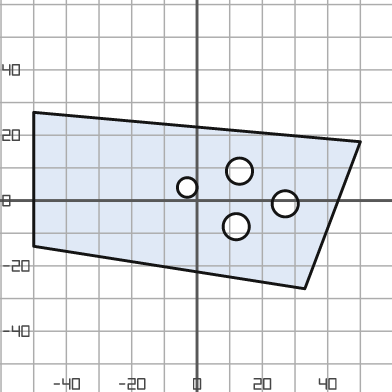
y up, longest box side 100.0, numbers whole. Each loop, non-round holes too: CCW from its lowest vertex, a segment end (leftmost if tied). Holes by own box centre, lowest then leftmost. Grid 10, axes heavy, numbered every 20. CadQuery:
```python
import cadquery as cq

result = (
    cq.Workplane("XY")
    .moveTo(33.0, -27.0)
    .lineTo(50.0, 18.0)
    .lineTo(-50.0, 27.0)
    .lineTo(-50.0, -14.0)
    .close()
    .moveTo(12.0, -8.0)
    .circle(4.0)
    .moveTo(27.0, -1.0)
    .circle(4.0)
    .moveTo(-3.0, 4.0)
    .circle(3.0)
    .moveTo(13.0, 9.0)
    .circle(4.0)
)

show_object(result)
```